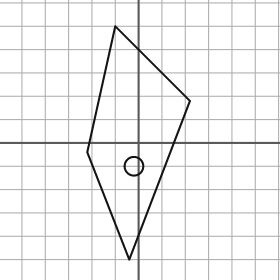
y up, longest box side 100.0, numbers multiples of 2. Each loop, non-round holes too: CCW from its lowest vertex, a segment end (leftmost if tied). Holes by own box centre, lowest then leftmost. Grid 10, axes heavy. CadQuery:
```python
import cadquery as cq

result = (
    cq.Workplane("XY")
    .moveTo(-4.0, -50.0)
    .lineTo(22.0, 18.0)
    .lineTo(-10.0, 50.0)
    .lineTo(-22.0, -4.0)
    .close()
    .moveTo(-2.0, -10.0)
    .circle(4.0)
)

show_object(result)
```